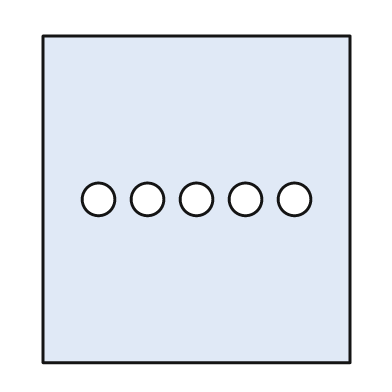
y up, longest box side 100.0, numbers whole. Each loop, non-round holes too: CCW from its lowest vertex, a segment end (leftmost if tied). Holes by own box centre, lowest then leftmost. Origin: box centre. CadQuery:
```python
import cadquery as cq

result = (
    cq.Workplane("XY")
    .moveTo(-47.0, -50.0)
    .lineTo(47.0, -50.0)
    .lineTo(47.0, 50.0)
    .lineTo(-47.0, 50.0)
    .close()
    .moveTo(-30.0, 0.0)
    .circle(5.0)
    .moveTo(-15.0, 0.0)
    .circle(5.0)
    .moveTo(0.0, 0.0)
    .circle(5.0)
    .moveTo(15.0, 0.0)
    .circle(5.0)
    .moveTo(30.0, 0.0)
    .circle(5.0)
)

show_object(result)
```